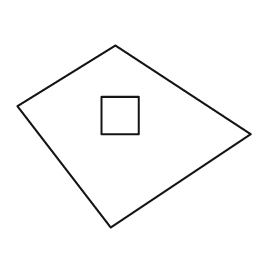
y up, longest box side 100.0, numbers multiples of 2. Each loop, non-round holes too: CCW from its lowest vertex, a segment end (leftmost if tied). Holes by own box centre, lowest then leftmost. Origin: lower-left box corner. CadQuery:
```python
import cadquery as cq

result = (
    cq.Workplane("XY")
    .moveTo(40.0, 0.0)
    .lineTo(100.0, 40.0)
    .lineTo(42.0, 78.0)
    .lineTo(0.0, 52.0)
    .close()
    .moveTo(36.0, 40.0)
    .lineTo(52.0, 40.0)
    .lineTo(52.0, 56.0)
    .lineTo(36.0, 56.0)
    .close()
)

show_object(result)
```